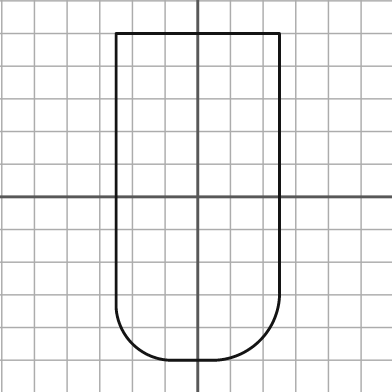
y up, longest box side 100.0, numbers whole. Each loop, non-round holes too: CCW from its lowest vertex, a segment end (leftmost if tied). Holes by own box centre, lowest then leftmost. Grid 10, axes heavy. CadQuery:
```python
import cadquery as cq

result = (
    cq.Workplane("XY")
    .moveTo(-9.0, -50.0)
    .lineTo(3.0, -50.0)
    .threePointArc((19.0, -44.0), (25.0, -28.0))
    .lineTo(25.0, 50.0)
    .lineTo(-25.0, 50.0)
    .lineTo(-25.0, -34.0)
    .threePointArc((-20.0, -45.0), (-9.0, -50.0))
    .close()
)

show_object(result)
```